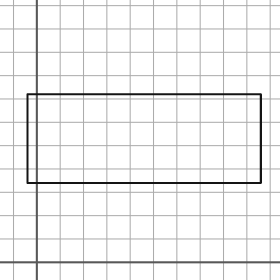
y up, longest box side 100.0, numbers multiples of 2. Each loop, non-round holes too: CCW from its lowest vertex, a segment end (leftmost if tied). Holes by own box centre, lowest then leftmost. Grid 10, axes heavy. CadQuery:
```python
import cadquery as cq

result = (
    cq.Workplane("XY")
    .moveTo(-4.0, 34.0)
    .lineTo(96.0, 34.0)
    .lineTo(96.0, 72.0)
    .lineTo(-4.0, 72.0)
    .close()
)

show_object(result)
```